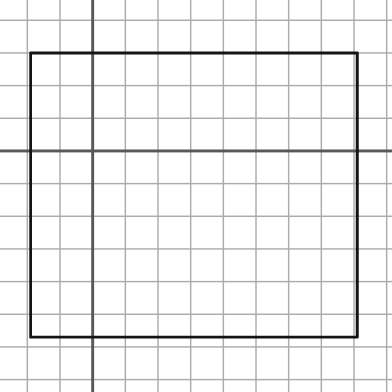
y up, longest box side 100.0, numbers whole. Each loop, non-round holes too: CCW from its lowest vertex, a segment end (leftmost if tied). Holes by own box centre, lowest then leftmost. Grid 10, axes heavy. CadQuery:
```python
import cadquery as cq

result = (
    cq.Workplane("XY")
    .moveTo(-19.0, -57.0)
    .lineTo(81.0, -57.0)
    .lineTo(81.0, 30.0)
    .lineTo(-19.0, 30.0)
    .close()
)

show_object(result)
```